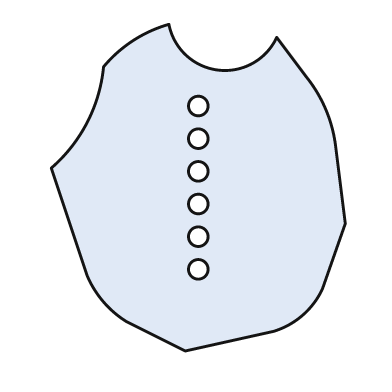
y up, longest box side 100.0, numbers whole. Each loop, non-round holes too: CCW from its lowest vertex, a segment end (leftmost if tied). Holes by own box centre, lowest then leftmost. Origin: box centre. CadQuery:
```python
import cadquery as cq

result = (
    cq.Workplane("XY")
    .moveTo(-4.0, -50.0)
    .lineTo(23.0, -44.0)
    .threePointArc((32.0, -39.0), (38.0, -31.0))
    .lineTo(45.0, -11.0)
    .lineTo(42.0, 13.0)
    .threePointArc((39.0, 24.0), (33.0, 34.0))
    .lineTo(24.0, 46.0)
    .threePointArc((6.0, 36.0), (-9.0, 50.0))
    .threePointArc((-20.0, 45.0), (-29.0, 37.0))
    .threePointArc((-34.0, 20.0), (-45.0, 6.0))
    .lineTo(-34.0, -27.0)
    .threePointArc((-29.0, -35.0), (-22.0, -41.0))
    .close()
    .moveTo(0.0, -25.0)
    .circle(3.0)
    .moveTo(0.0, -15.0)
    .circle(3.0)
    .moveTo(0.0, -5.0)
    .circle(3.0)
    .moveTo(0.0, 5.0)
    .circle(3.0)
    .moveTo(0.0, 15.0)
    .circle(3.0)
    .moveTo(0.0, 25.0)
    .circle(3.0)
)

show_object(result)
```